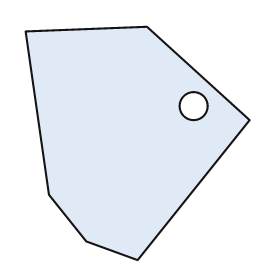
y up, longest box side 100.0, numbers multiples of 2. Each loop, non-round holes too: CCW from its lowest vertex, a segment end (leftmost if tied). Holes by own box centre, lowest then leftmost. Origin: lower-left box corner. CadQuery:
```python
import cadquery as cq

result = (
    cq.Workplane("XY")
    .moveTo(48.0, 0.0)
    .lineTo(96.0, 60.0)
    .lineTo(52.0, 100.0)
    .lineTo(0.0, 98.0)
    .lineTo(10.0, 28.0)
    .lineTo(26.0, 8.0)
    .close()
    .moveTo(72.0, 66.0)
    .circle(6.0)
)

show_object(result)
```